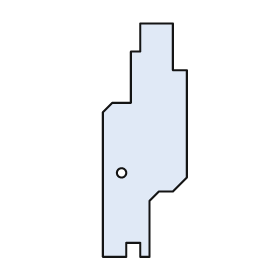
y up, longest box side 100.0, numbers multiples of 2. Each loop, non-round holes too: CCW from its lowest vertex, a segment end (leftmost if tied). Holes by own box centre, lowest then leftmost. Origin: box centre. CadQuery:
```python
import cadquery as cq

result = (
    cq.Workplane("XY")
    .moveTo(-18.0, -50.0)
    .lineTo(-8.0, -50.0)
    .lineTo(-8.0, -44.0)
    .lineTo(-2.0, -44.0)
    .lineTo(-2.0, -50.0)
    .lineTo(2.0, -50.0)
    .lineTo(2.0, -26.0)
    .lineTo(6.0, -22.0)
    .lineTo(12.0, -22.0)
    .lineTo(18.0, -16.0)
    .lineTo(18.0, 30.0)
    .lineTo(12.0, 30.0)
    .lineTo(12.0, 50.0)
    .lineTo(-2.0, 50.0)
    .lineTo(-2.0, 38.0)
    .lineTo(-6.0, 38.0)
    .lineTo(-6.0, 16.0)
    .lineTo(-14.0, 16.0)
    .lineTo(-18.0, 12.0)
    .close()
    .moveTo(-10.0, -14.0)
    .circle(2.0)
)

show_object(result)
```